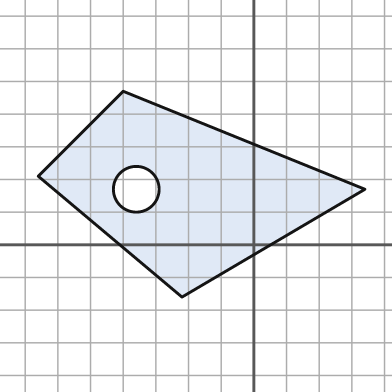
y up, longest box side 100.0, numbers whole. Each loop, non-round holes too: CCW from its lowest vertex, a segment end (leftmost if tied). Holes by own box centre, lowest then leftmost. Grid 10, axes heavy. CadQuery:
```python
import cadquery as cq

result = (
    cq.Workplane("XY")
    .moveTo(-22.0, -16.0)
    .lineTo(34.0, 17.0)
    .lineTo(-40.0, 47.0)
    .lineTo(-66.0, 21.0)
    .close()
    .moveTo(-36.0, 17.0)
    .circle(7.0)
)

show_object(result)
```